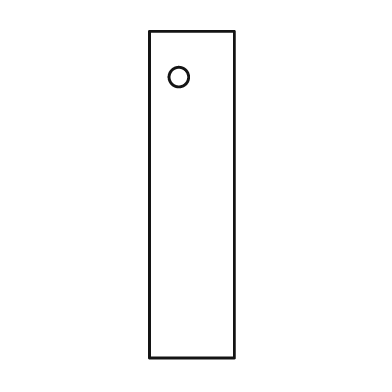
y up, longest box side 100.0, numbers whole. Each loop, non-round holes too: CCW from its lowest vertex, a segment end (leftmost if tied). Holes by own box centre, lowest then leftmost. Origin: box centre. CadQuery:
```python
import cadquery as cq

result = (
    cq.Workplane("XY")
    .moveTo(-13.0, -50.0)
    .lineTo(13.0, -50.0)
    .lineTo(13.0, 50.0)
    .lineTo(-13.0, 50.0)
    .close()
    .moveTo(-4.0, 36.0)
    .circle(3.0)
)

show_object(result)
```